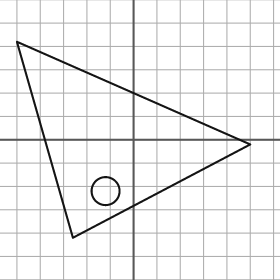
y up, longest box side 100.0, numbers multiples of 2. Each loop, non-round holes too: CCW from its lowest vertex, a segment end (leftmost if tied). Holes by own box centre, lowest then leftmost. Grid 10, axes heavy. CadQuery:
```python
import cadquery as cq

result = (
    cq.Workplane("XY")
    .moveTo(-26.0, -42.0)
    .lineTo(50.0, -2.0)
    .lineTo(-50.0, 42.0)
    .close()
    .moveTo(-12.0, -22.0)
    .circle(6.0)
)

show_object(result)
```